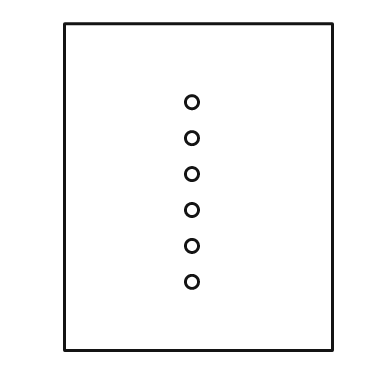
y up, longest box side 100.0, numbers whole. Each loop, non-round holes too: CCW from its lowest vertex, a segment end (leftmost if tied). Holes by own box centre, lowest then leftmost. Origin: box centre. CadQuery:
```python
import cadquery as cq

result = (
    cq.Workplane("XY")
    .moveTo(-41.0, -50.0)
    .lineTo(41.0, -50.0)
    .lineTo(41.0, 50.0)
    .lineTo(-41.0, 50.0)
    .close()
    .moveTo(-2.0, -29.0)
    .circle(2.0)
    .moveTo(-2.0, -18.0)
    .circle(2.0)
    .moveTo(-2.0, -7.0)
    .circle(2.0)
    .moveTo(-2.0, 4.0)
    .circle(2.0)
    .moveTo(-2.0, 15.0)
    .circle(2.0)
    .moveTo(-2.0, 26.0)
    .circle(2.0)
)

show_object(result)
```